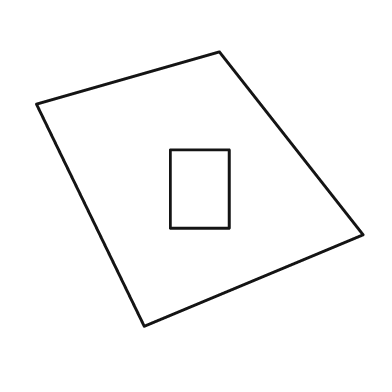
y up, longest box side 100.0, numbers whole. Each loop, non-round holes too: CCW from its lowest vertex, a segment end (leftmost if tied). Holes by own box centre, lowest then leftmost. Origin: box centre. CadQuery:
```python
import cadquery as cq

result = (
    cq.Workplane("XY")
    .moveTo(-17.0, -42.0)
    .lineTo(50.0, -14.0)
    .lineTo(6.0, 42.0)
    .lineTo(-50.0, 26.0)
    .close()
    .moveTo(-9.0, -12.0)
    .lineTo(9.0, -12.0)
    .lineTo(9.0, 12.0)
    .lineTo(-9.0, 12.0)
    .close()
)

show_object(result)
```